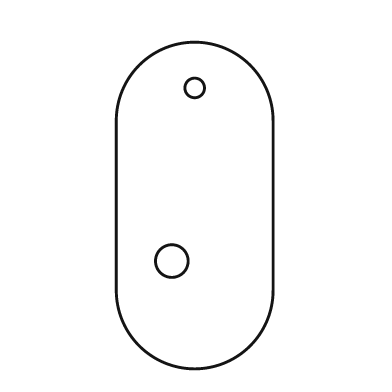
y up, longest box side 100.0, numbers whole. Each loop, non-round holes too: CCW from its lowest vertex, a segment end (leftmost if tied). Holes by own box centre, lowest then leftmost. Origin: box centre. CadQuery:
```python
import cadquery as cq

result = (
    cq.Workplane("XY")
    .moveTo(-24.0, -26.0)
    .threePointArc((0.0, -50.0), (24.0, -26.0))
    .lineTo(24.0, 26.0)
    .threePointArc((0.0, 50.0), (-24.0, 26.0))
    .close()
    .moveTo(-7.0, -17.0)
    .circle(5.0)
    .moveTo(0.0, 36.0)
    .circle(3.0)
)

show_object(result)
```